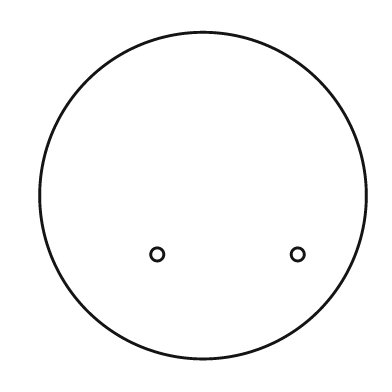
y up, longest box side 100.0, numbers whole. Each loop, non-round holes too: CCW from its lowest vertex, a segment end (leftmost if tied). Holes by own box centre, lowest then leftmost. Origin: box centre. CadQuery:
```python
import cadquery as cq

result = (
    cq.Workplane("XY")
    .moveTo(0.0, 0.0)
    .circle(50.0)
    .moveTo(-14.0, -18.0)
    .circle(2.0)
    .moveTo(29.0, -18.0)
    .circle(2.0)
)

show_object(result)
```